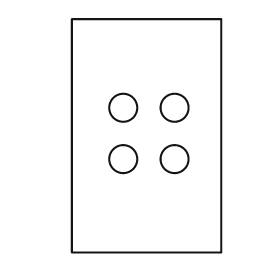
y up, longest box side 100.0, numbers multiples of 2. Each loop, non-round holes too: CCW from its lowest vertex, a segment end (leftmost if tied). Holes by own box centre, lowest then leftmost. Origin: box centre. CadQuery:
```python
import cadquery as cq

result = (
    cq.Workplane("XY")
    .moveTo(-32.0, -50.0)
    .lineTo(32.0, -50.0)
    .lineTo(32.0, 50.0)
    .lineTo(-32.0, 50.0)
    .close()
    .moveTo(-10.0, -10.0)
    .circle(6.0)
    .moveTo(12.0, -10.0)
    .circle(6.0)
    .moveTo(-10.0, 12.0)
    .circle(6.0)
    .moveTo(12.0, 12.0)
    .circle(6.0)
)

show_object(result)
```